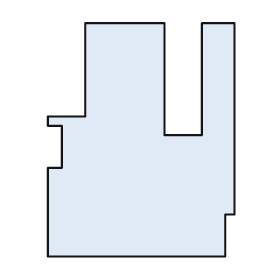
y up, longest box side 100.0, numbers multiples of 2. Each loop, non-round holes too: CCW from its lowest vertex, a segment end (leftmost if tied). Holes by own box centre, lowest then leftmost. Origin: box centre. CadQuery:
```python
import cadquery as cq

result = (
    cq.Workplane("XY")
    .moveTo(-40.0, -50.0)
    .lineTo(36.0, -50.0)
    .lineTo(36.0, -32.0)
    .lineTo(40.0, -32.0)
    .lineTo(40.0, 50.0)
    .lineTo(26.0, 50.0)
    .lineTo(26.0, 2.0)
    .lineTo(10.0, 2.0)
    .lineTo(10.0, 50.0)
    .lineTo(-24.0, 50.0)
    .lineTo(-24.0, 10.0)
    .lineTo(-40.0, 10.0)
    .lineTo(-40.0, 6.0)
    .lineTo(-34.0, 6.0)
    .lineTo(-34.0, -12.0)
    .lineTo(-40.0, -12.0)
    .close()
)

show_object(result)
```